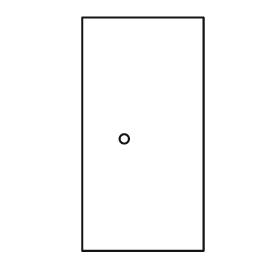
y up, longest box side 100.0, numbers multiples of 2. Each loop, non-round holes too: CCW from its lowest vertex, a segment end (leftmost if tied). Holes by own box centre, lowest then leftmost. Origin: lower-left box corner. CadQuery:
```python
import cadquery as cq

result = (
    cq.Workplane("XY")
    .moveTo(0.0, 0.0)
    .lineTo(52.0, 0.0)
    .lineTo(52.0, 100.0)
    .lineTo(0.0, 100.0)
    .close()
    .moveTo(18.0, 48.0)
    .circle(2.0)
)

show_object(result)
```